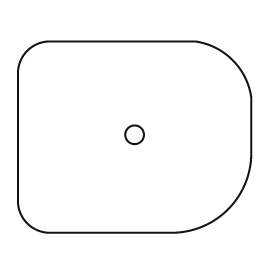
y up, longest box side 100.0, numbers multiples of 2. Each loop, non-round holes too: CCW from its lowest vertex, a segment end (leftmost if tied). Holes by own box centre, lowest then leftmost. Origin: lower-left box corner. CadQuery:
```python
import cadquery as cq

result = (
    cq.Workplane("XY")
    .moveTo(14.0, 0.0)
    .lineTo(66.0, 0.0)
    .threePointArc((90.0, 10.0), (100.0, 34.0))
    .lineTo(100.0, 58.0)
    .threePointArc((92.0, 74.0), (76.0, 82.0))
    .lineTo(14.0, 82.0)
    .threePointArc((4.0, 78.0), (0.0, 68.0))
    .lineTo(0.0, 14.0)
    .threePointArc((4.0, 4.0), (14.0, 0.0))
    .close()
    .moveTo(50.0, 42.0)
    .circle(4.0)
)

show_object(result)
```